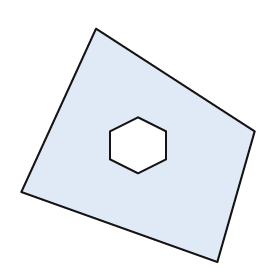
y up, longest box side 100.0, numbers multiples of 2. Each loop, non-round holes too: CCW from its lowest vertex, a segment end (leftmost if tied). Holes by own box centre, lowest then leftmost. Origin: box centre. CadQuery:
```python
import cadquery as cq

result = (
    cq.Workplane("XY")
    .moveTo(34.0, -50.0)
    .lineTo(50.0, 6.0)
    .lineTo(-18.0, 50.0)
    .lineTo(-50.0, -20.0)
    .close()
    .moveTo(0.0, -12.0)
    .lineTo(12.0, -6.0)
    .lineTo(12.0, 6.0)
    .lineTo(0.0, 12.0)
    .lineTo(-12.0, 6.0)
    .lineTo(-12.0, -6.0)
    .close()
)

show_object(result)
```